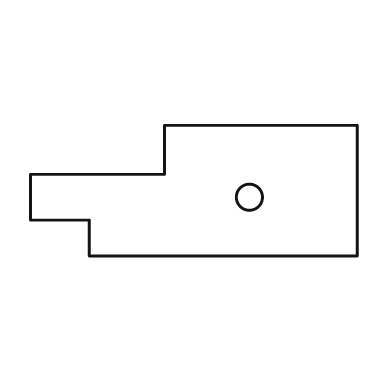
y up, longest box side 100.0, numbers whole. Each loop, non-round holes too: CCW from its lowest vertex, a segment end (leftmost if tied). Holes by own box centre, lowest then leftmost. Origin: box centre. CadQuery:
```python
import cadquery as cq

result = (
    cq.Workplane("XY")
    .moveTo(-32.0, -20.0)
    .lineTo(50.0, -20.0)
    .lineTo(50.0, 20.0)
    .lineTo(-9.0, 20.0)
    .lineTo(-9.0, 5.0)
    .lineTo(-50.0, 5.0)
    .lineTo(-50.0, -9.0)
    .lineTo(-32.0, -9.0)
    .close()
    .moveTo(17.0, -2.0)
    .circle(4.0)
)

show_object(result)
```